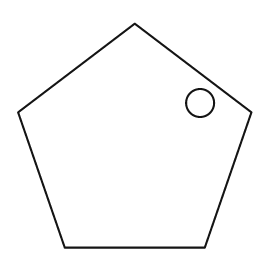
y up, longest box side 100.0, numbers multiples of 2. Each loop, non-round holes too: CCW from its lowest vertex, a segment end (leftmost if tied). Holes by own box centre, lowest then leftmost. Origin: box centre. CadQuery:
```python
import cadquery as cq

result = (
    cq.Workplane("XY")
    .moveTo(-30.0, -48.0)
    .lineTo(30.0, -48.0)
    .lineTo(50.0, 10.0)
    .lineTo(0.0, 48.0)
    .lineTo(-50.0, 10.0)
    .close()
    .moveTo(28.0, 14.0)
    .circle(6.0)
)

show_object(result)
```